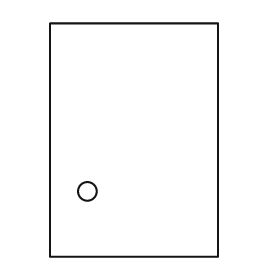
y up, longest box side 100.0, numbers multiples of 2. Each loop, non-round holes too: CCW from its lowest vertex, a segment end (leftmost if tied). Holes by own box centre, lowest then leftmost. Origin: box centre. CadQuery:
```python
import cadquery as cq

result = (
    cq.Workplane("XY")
    .moveTo(-36.0, -50.0)
    .lineTo(36.0, -50.0)
    .lineTo(36.0, 50.0)
    .lineTo(-36.0, 50.0)
    .close()
    .moveTo(-20.0, -22.0)
    .circle(4.0)
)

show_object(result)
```